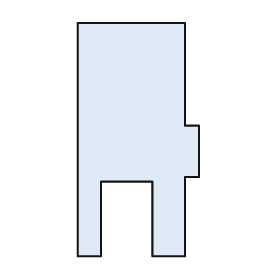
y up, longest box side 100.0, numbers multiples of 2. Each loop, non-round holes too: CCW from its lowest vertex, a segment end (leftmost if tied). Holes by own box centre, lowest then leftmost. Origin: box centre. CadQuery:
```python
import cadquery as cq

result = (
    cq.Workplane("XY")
    .moveTo(-26.0, -50.0)
    .lineTo(-16.0, -50.0)
    .lineTo(-16.0, -18.0)
    .lineTo(6.0, -18.0)
    .lineTo(6.0, -50.0)
    .lineTo(20.0, -50.0)
    .lineTo(20.0, -16.0)
    .lineTo(26.0, -16.0)
    .lineTo(26.0, 6.0)
    .lineTo(20.0, 6.0)
    .lineTo(20.0, 50.0)
    .lineTo(-26.0, 50.0)
    .close()
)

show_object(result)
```